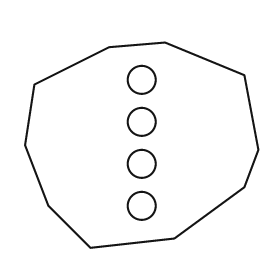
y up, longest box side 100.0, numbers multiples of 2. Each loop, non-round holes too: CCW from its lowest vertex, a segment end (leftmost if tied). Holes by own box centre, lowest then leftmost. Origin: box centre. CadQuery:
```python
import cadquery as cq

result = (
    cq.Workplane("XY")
    .moveTo(-22.0, -44.0)
    .lineTo(14.0, -40.0)
    .lineTo(44.0, -18.0)
    .lineTo(50.0, -2.0)
    .lineTo(44.0, 30.0)
    .lineTo(10.0, 44.0)
    .lineTo(-14.0, 42.0)
    .lineTo(-46.0, 26.0)
    .lineTo(-50.0, 0.0)
    .lineTo(-40.0, -26.0)
    .close()
    .moveTo(0.0, -26.0)
    .circle(6.0)
    .moveTo(0.0, -8.0)
    .circle(6.0)
    .moveTo(0.0, 10.0)
    .circle(6.0)
    .moveTo(0.0, 28.0)
    .circle(6.0)
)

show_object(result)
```